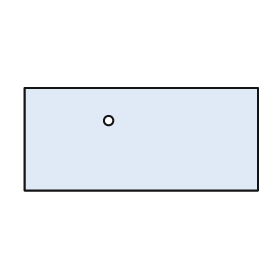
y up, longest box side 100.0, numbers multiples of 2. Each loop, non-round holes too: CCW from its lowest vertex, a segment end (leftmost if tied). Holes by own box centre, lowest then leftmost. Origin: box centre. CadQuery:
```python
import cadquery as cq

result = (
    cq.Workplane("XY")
    .moveTo(-50.0, -22.0)
    .lineTo(50.0, -22.0)
    .lineTo(50.0, 22.0)
    .lineTo(-50.0, 22.0)
    .close()
    .moveTo(-14.0, 8.0)
    .circle(2.0)
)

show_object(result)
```